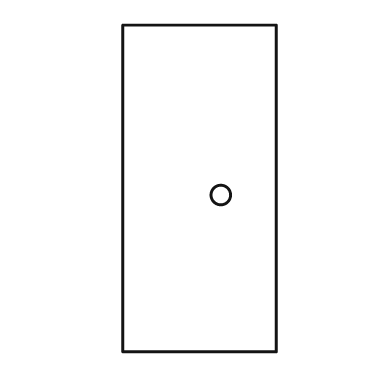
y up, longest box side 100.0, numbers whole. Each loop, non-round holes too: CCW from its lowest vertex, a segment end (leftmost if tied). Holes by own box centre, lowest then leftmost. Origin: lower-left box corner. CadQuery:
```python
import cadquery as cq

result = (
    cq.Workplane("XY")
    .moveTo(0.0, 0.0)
    .lineTo(47.0, 0.0)
    .lineTo(47.0, 100.0)
    .lineTo(0.0, 100.0)
    .close()
    .moveTo(30.0, 48.0)
    .circle(3.0)
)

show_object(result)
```